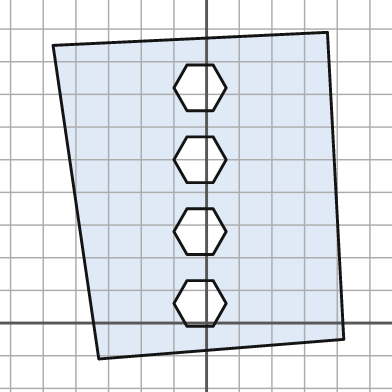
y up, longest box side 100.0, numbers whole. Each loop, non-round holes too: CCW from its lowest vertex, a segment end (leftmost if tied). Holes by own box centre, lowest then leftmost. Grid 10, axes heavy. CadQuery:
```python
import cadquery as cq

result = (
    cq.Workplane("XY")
    .moveTo(-33.0, -11.0)
    .lineTo(42.0, -5.0)
    .lineTo(37.0, 89.0)
    .lineTo(-47.0, 85.0)
    .close()
    .moveTo(-6.0, -1.0)
    .lineTo(2.0, -1.0)
    .lineTo(6.0, 6.0)
    .lineTo(2.0, 13.0)
    .lineTo(-6.0, 13.0)
    .lineTo(-10.0, 6.0)
    .close()
    .moveTo(-6.0, 21.0)
    .lineTo(2.0, 21.0)
    .lineTo(6.0, 28.0)
    .lineTo(2.0, 35.0)
    .lineTo(-6.0, 35.0)
    .lineTo(-10.0, 28.0)
    .close()
    .moveTo(-6.0, 43.0)
    .lineTo(2.0, 43.0)
    .lineTo(6.0, 50.0)
    .lineTo(2.0, 57.0)
    .lineTo(-6.0, 57.0)
    .lineTo(-10.0, 50.0)
    .close()
    .moveTo(-6.0, 65.0)
    .lineTo(2.0, 65.0)
    .lineTo(6.0, 72.0)
    .lineTo(2.0, 79.0)
    .lineTo(-6.0, 79.0)
    .lineTo(-10.0, 72.0)
    .close()
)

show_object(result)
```